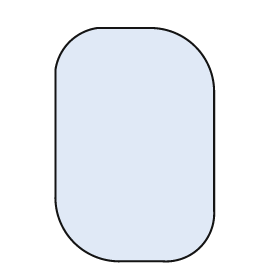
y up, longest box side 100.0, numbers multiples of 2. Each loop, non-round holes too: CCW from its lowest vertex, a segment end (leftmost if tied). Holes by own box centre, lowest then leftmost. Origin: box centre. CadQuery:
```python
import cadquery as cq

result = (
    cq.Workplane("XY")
    .moveTo(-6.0, -50.0)
    .lineTo(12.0, -50.0)
    .threePointArc((28.0, -44.0), (34.0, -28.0))
    .lineTo(34.0, 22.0)
    .threePointArc((26.0, 42.0), (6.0, 50.0))
    .lineTo(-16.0, 50.0)
    .threePointArc((-28.0, 44.0), (-34.0, 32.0))
    .lineTo(-34.0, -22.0)
    .threePointArc((-26.0, -42.0), (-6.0, -50.0))
    .close()
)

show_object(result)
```